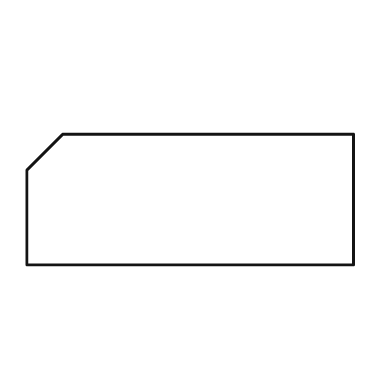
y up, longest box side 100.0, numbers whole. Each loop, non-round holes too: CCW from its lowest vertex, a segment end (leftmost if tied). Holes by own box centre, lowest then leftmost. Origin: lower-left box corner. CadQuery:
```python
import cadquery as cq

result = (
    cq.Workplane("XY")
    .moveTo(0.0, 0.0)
    .lineTo(100.0, 0.0)
    .lineTo(100.0, 40.0)
    .lineTo(11.0, 40.0)
    .lineTo(0.0, 29.0)
    .close()
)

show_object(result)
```